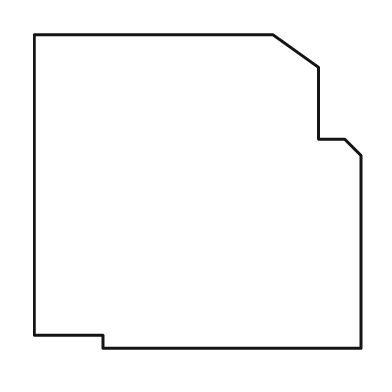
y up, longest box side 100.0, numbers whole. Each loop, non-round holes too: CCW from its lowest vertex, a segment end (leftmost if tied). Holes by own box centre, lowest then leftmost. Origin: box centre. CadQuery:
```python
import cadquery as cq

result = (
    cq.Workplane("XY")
    .moveTo(-29.0, -48.0)
    .lineTo(50.0, -48.0)
    .lineTo(50.0, 11.0)
    .lineTo(45.0, 16.0)
    .lineTo(37.0, 16.0)
    .lineTo(37.0, 38.0)
    .lineTo(23.0, 48.0)
    .lineTo(-50.0, 48.0)
    .lineTo(-50.0, -44.0)
    .lineTo(-29.0, -44.0)
    .close()
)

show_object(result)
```